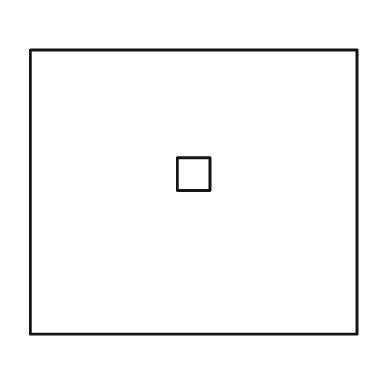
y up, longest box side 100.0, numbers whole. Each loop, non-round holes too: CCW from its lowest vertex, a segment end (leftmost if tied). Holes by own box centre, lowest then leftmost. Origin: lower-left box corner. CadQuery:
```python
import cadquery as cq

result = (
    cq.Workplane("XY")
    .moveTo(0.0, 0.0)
    .lineTo(100.0, 0.0)
    .lineTo(100.0, 87.0)
    .lineTo(0.0, 87.0)
    .close()
    .moveTo(45.0, 44.0)
    .lineTo(55.0, 44.0)
    .lineTo(55.0, 54.0)
    .lineTo(45.0, 54.0)
    .close()
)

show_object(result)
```